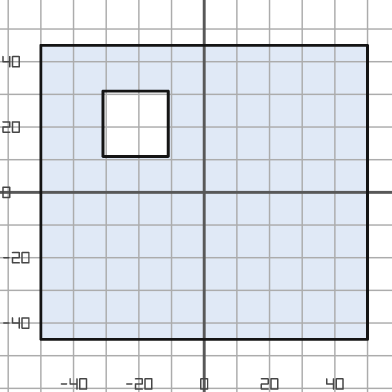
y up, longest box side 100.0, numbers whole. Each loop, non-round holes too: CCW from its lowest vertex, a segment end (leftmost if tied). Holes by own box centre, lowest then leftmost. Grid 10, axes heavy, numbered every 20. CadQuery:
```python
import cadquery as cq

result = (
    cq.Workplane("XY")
    .moveTo(-50.0, -45.0)
    .lineTo(50.0, -45.0)
    .lineTo(50.0, 45.0)
    .lineTo(-50.0, 45.0)
    .close()
    .moveTo(-31.0, 11.0)
    .lineTo(-11.0, 11.0)
    .lineTo(-11.0, 31.0)
    .lineTo(-31.0, 31.0)
    .close()
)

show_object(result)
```